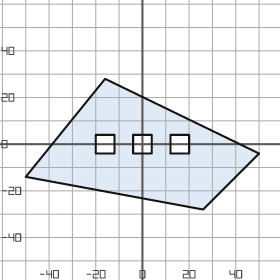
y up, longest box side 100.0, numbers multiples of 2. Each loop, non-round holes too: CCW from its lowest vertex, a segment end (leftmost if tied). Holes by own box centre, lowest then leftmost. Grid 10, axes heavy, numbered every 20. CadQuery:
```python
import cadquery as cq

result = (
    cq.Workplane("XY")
    .moveTo(26.0, -28.0)
    .lineTo(50.0, -4.0)
    .lineTo(-16.0, 28.0)
    .lineTo(-50.0, -14.0)
    .close()
    .moveTo(-20.0, -4.0)
    .lineTo(-12.0, -4.0)
    .lineTo(-12.0, 4.0)
    .lineTo(-20.0, 4.0)
    .close()
    .moveTo(-4.0, -4.0)
    .lineTo(4.0, -4.0)
    .lineTo(4.0, 4.0)
    .lineTo(-4.0, 4.0)
    .close()
    .moveTo(12.0, -4.0)
    .lineTo(20.0, -4.0)
    .lineTo(20.0, 4.0)
    .lineTo(12.0, 4.0)
    .close()
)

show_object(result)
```